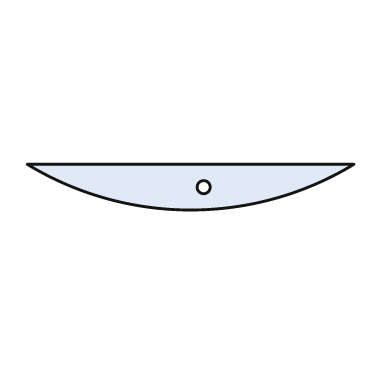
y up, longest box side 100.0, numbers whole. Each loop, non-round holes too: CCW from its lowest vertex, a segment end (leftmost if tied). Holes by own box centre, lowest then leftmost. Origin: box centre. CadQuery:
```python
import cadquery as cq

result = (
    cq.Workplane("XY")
    .moveTo(-50.0, 7.0)
    .threePointArc((0.0, -7.0), (50.0, 7.0))
    .close()
    .moveTo(4.0, 0.0)
    .circle(2.0)
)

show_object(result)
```